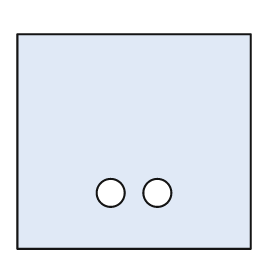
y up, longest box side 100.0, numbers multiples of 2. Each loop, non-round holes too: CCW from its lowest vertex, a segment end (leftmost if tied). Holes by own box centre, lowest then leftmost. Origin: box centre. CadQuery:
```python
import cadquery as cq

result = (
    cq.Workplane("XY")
    .moveTo(-50.0, -46.0)
    .lineTo(50.0, -46.0)
    .lineTo(50.0, 46.0)
    .lineTo(-50.0, 46.0)
    .close()
    .moveTo(-10.0, -22.0)
    .circle(6.0)
    .moveTo(10.0, -22.0)
    .circle(6.0)
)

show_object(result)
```